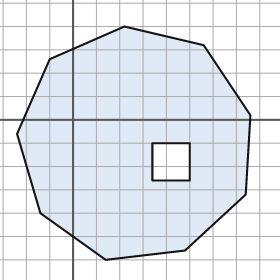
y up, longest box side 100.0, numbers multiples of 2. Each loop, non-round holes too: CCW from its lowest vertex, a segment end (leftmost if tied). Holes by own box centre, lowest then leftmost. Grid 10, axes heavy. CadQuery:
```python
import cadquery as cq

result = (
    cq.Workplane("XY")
    .moveTo(14.0, -60.0)
    .lineTo(48.0, -56.0)
    .lineTo(74.0, -32.0)
    .lineTo(76.0, 2.0)
    .lineTo(56.0, 32.0)
    .lineTo(22.0, 40.0)
    .lineTo(-10.0, 26.0)
    .lineTo(-24.0, -6.0)
    .lineTo(-14.0, -40.0)
    .close()
    .moveTo(34.0, -26.0)
    .lineTo(50.0, -26.0)
    .lineTo(50.0, -10.0)
    .lineTo(34.0, -10.0)
    .close()
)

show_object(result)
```